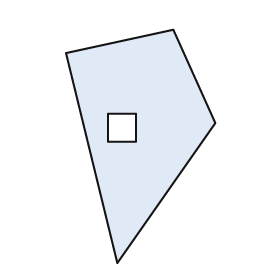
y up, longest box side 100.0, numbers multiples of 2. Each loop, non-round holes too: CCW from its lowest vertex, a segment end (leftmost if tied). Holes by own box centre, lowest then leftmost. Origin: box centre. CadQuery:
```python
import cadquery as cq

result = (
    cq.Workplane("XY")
    .moveTo(-10.0, -50.0)
    .lineTo(32.0, 10.0)
    .lineTo(14.0, 50.0)
    .lineTo(-32.0, 40.0)
    .close()
    .moveTo(-14.0, 2.0)
    .lineTo(-2.0, 2.0)
    .lineTo(-2.0, 14.0)
    .lineTo(-14.0, 14.0)
    .close()
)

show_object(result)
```